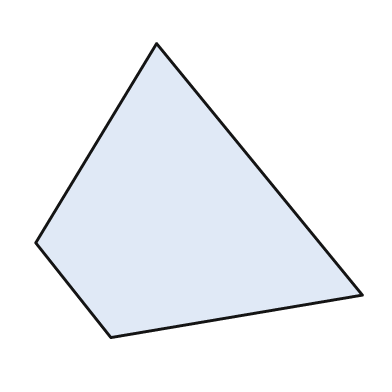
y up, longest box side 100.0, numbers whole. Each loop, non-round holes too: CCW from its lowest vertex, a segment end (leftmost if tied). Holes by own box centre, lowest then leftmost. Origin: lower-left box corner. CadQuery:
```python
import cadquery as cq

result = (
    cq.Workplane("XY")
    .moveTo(23.0, 0.0)
    .lineTo(100.0, 13.0)
    .lineTo(37.0, 90.0)
    .lineTo(0.0, 29.0)
    .close()
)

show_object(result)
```